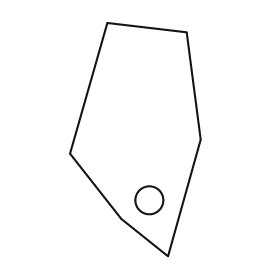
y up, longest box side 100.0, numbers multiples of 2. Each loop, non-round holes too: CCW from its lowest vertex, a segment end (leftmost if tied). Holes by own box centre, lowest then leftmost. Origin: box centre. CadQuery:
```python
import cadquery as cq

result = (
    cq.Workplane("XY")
    .moveTo(14.0, -50.0)
    .lineTo(28.0, 0.0)
    .lineTo(22.0, 46.0)
    .lineTo(-12.0, 50.0)
    .lineTo(-28.0, -6.0)
    .lineTo(-6.0, -34.0)
    .close()
    .moveTo(6.0, -26.0)
    .circle(6.0)
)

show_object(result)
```